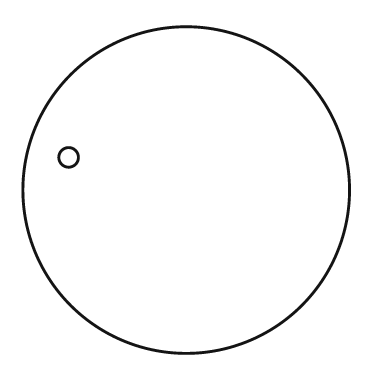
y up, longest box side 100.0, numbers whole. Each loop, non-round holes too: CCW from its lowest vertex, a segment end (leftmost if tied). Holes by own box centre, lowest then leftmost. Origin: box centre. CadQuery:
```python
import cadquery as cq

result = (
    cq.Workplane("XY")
    .moveTo(0.0, 0.0)
    .circle(50.0)
    .moveTo(-36.0, 10.0)
    .circle(3.0)
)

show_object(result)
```